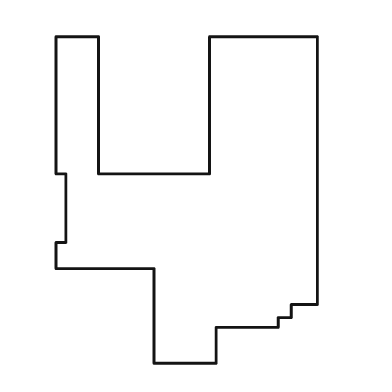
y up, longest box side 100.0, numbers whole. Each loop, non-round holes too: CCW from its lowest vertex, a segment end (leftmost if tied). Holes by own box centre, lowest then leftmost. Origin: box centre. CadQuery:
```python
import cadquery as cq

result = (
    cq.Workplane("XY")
    .moveTo(-10.0, -50.0)
    .lineTo(9.0, -50.0)
    .lineTo(9.0, -39.0)
    .lineTo(28.0, -39.0)
    .lineTo(28.0, -36.0)
    .lineTo(32.0, -36.0)
    .lineTo(32.0, -32.0)
    .lineTo(40.0, -32.0)
    .lineTo(40.0, 50.0)
    .lineTo(7.0, 50.0)
    .lineTo(7.0, 8.0)
    .lineTo(-27.0, 8.0)
    .lineTo(-27.0, 50.0)
    .lineTo(-40.0, 50.0)
    .lineTo(-40.0, 8.0)
    .lineTo(-37.0, 8.0)
    .lineTo(-37.0, -13.0)
    .lineTo(-40.0, -13.0)
    .lineTo(-40.0, -21.0)
    .lineTo(-10.0, -21.0)
    .close()
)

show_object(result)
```